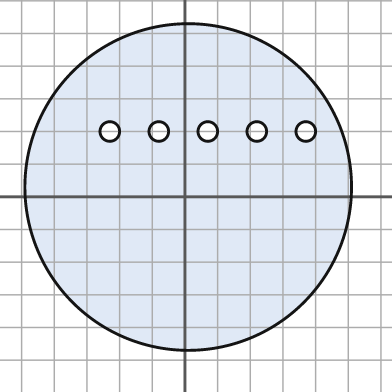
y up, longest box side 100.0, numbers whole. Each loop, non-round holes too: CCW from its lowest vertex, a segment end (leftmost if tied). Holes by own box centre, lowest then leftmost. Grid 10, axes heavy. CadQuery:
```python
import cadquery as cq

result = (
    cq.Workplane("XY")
    .moveTo(1.0, 3.0)
    .circle(50.0)
    .moveTo(-23.0, 20.0)
    .circle(3.0)
    .moveTo(-8.0, 20.0)
    .circle(3.0)
    .moveTo(7.0, 20.0)
    .circle(3.0)
    .moveTo(22.0, 20.0)
    .circle(3.0)
    .moveTo(37.0, 20.0)
    .circle(3.0)
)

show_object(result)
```